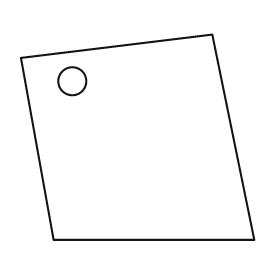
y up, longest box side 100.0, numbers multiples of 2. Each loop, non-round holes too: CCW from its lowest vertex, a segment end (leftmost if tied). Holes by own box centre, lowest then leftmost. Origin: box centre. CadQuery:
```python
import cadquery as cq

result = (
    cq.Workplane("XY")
    .moveTo(-36.0, -44.0)
    .lineTo(50.0, -44.0)
    .lineTo(32.0, 44.0)
    .lineTo(-50.0, 34.0)
    .close()
    .moveTo(-28.0, 24.0)
    .circle(6.0)
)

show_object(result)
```